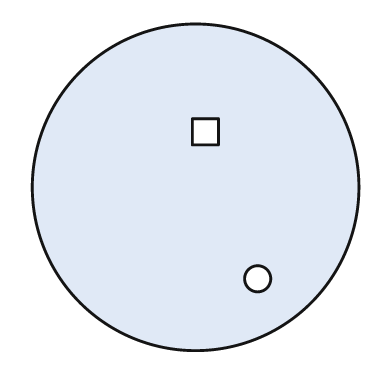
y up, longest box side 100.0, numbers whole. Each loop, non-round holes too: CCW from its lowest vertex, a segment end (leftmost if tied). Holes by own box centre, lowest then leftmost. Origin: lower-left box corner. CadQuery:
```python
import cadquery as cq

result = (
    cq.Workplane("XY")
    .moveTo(50.0, 50.0)
    .circle(50.0)
    .moveTo(69.0, 22.0)
    .circle(4.0)
    .moveTo(49.0, 63.0)
    .lineTo(57.0, 63.0)
    .lineTo(57.0, 71.0)
    .lineTo(49.0, 71.0)
    .close()
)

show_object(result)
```